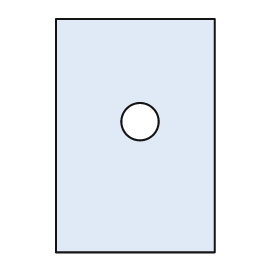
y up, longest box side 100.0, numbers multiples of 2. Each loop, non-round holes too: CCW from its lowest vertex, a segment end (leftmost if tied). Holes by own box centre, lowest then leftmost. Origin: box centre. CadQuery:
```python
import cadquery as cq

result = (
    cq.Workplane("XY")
    .moveTo(-34.0, -50.0)
    .lineTo(34.0, -50.0)
    .lineTo(34.0, 50.0)
    .lineTo(-34.0, 50.0)
    .close()
    .moveTo(2.0, 6.0)
    .circle(8.0)
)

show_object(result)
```